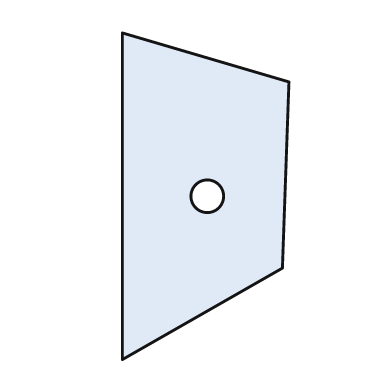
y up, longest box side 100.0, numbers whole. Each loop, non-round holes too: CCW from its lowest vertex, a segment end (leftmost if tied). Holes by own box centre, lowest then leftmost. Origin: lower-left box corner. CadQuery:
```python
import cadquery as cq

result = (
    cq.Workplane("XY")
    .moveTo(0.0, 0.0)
    .lineTo(49.0, 28.0)
    .lineTo(51.0, 85.0)
    .lineTo(0.0, 100.0)
    .close()
    .moveTo(26.0, 50.0)
    .circle(5.0)
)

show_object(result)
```